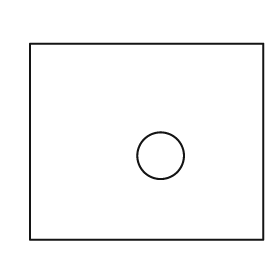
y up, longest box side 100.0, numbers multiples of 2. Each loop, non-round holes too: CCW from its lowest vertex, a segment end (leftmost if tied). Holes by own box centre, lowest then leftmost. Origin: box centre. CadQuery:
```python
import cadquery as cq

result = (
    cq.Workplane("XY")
    .moveTo(-50.0, -42.0)
    .lineTo(50.0, -42.0)
    .lineTo(50.0, 42.0)
    .lineTo(-50.0, 42.0)
    .close()
    .moveTo(6.0, -6.0)
    .circle(10.0)
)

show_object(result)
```